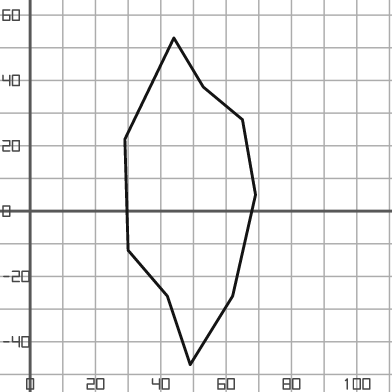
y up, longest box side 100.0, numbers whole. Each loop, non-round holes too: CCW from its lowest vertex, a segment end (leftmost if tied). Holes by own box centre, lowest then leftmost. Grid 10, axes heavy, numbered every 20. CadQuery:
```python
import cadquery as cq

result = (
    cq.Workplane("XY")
    .moveTo(49.0, -47.0)
    .lineTo(62.0, -26.0)
    .lineTo(69.0, 5.0)
    .lineTo(65.0, 28.0)
    .lineTo(53.0, 38.0)
    .lineTo(44.0, 53.0)
    .lineTo(29.0, 22.0)
    .lineTo(30.0, -12.0)
    .lineTo(42.0, -26.0)
    .close()
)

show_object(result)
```